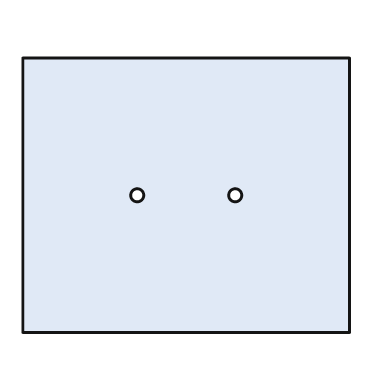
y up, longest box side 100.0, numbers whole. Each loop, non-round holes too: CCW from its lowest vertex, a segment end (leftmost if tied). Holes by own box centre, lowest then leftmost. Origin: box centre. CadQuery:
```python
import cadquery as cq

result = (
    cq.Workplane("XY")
    .moveTo(-50.0, -42.0)
    .lineTo(50.0, -42.0)
    .lineTo(50.0, 42.0)
    .lineTo(-50.0, 42.0)
    .close()
    .moveTo(-15.0, 0.0)
    .circle(2.0)
    .moveTo(15.0, 0.0)
    .circle(2.0)
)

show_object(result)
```